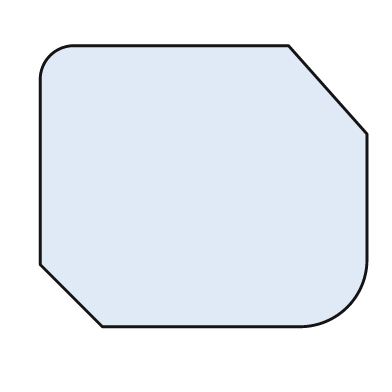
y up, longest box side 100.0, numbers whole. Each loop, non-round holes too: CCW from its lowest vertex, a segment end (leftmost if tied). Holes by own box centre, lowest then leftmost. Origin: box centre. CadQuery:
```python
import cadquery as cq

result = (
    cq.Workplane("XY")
    .moveTo(-31.0, -43.0)
    .lineTo(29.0, -43.0)
    .threePointArc((44.0, -37.0), (50.0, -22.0))
    .lineTo(50.0, 16.0)
    .lineTo(26.0, 43.0)
    .lineTo(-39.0, 43.0)
    .threePointArc((-47.0, 40.0), (-50.0, 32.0))
    .lineTo(-50.0, -24.0)
    .close()
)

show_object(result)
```